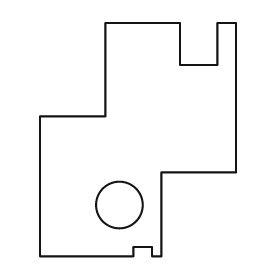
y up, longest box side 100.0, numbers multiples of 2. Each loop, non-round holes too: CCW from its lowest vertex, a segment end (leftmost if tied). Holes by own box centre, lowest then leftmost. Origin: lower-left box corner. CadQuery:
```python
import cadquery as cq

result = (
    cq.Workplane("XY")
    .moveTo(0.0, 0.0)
    .lineTo(40.0, 0.0)
    .lineTo(40.0, 4.0)
    .lineTo(48.0, 4.0)
    .lineTo(48.0, 0.0)
    .lineTo(52.0, 0.0)
    .lineTo(52.0, 36.0)
    .lineTo(84.0, 36.0)
    .lineTo(84.0, 100.0)
    .lineTo(76.0, 100.0)
    .lineTo(76.0, 82.0)
    .lineTo(60.0, 82.0)
    .lineTo(60.0, 100.0)
    .lineTo(28.0, 100.0)
    .lineTo(28.0, 60.0)
    .lineTo(0.0, 60.0)
    .close()
    .moveTo(34.0, 22.0)
    .circle(10.0)
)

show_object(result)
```